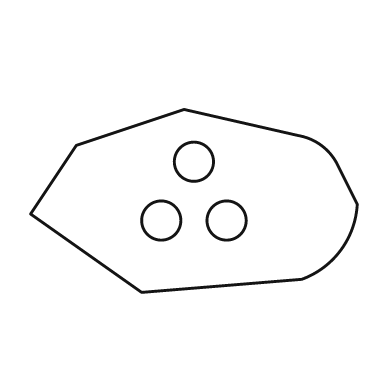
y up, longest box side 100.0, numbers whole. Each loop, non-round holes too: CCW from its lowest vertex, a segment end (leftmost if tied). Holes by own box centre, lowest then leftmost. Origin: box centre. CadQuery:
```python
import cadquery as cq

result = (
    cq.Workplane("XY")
    .moveTo(-16.0, -28.0)
    .lineTo(33.0, -24.0)
    .threePointArc((45.0, -15.0), (50.0, -1.0))
    .lineTo(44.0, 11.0)
    .threePointArc((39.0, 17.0), (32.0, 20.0))
    .lineTo(-3.0, 28.0)
    .lineTo(-36.0, 17.0)
    .lineTo(-50.0, -4.0)
    .close()
    .moveTo(-10.0, -6.0)
    .circle(6.0)
    .moveTo(10.0, -6.0)
    .circle(6.0)
    .moveTo(0.0, 12.0)
    .circle(6.0)
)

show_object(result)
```